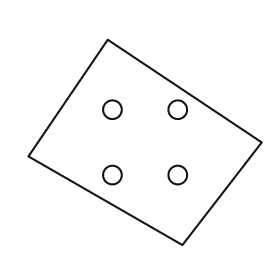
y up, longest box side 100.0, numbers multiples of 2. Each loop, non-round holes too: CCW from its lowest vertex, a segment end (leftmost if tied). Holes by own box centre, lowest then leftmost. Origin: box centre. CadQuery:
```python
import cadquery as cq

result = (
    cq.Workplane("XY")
    .moveTo(16.0, -44.0)
    .lineTo(50.0, 0.0)
    .lineTo(-16.0, 44.0)
    .lineTo(-50.0, -6.0)
    .close()
    .moveTo(-14.0, -14.0)
    .circle(4.0)
    .moveTo(14.0, -14.0)
    .circle(4.0)
    .moveTo(-14.0, 14.0)
    .circle(4.0)
    .moveTo(14.0, 14.0)
    .circle(4.0)
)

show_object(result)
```